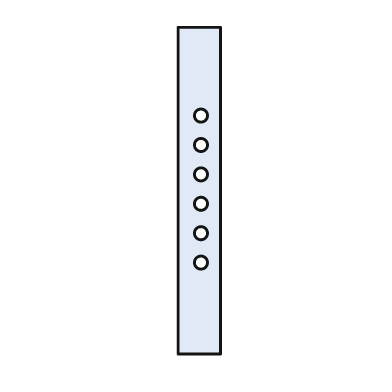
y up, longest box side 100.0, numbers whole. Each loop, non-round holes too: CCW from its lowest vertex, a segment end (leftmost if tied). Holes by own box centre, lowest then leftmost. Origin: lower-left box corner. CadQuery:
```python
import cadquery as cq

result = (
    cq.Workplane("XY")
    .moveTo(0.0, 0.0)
    .lineTo(13.0, 0.0)
    .lineTo(13.0, 100.0)
    .lineTo(0.0, 100.0)
    .close()
    .moveTo(7.0, 28.0)
    .circle(2.0)
    .moveTo(7.0, 37.0)
    .circle(2.0)
    .moveTo(7.0, 46.0)
    .circle(2.0)
    .moveTo(7.0, 55.0)
    .circle(2.0)
    .moveTo(7.0, 64.0)
    .circle(2.0)
    .moveTo(7.0, 73.0)
    .circle(2.0)
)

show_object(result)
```